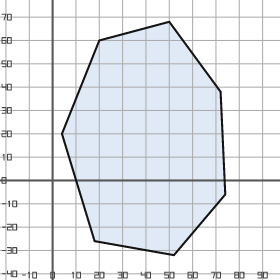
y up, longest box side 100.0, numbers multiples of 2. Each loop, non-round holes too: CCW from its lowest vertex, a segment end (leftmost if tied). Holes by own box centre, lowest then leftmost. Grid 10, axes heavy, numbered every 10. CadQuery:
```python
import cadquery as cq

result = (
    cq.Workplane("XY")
    .moveTo(52.0, -32.0)
    .lineTo(74.0, -6.0)
    .lineTo(72.0, 38.0)
    .lineTo(50.0, 68.0)
    .lineTo(20.0, 60.0)
    .lineTo(4.0, 20.0)
    .lineTo(18.0, -26.0)
    .close()
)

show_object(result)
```